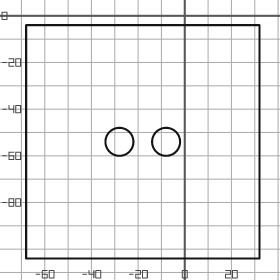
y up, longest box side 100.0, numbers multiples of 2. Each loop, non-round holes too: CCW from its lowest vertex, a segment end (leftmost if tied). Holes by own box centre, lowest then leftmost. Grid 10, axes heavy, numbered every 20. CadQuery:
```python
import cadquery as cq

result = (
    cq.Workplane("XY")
    .moveTo(-68.0, -104.0)
    .lineTo(32.0, -104.0)
    .lineTo(32.0, -4.0)
    .lineTo(-68.0, -4.0)
    .close()
    .moveTo(-28.0, -54.0)
    .circle(6.0)
    .moveTo(-8.0, -54.0)
    .circle(6.0)
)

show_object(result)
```